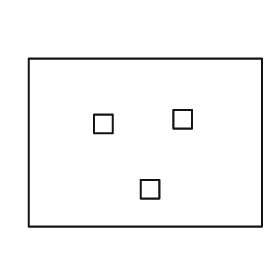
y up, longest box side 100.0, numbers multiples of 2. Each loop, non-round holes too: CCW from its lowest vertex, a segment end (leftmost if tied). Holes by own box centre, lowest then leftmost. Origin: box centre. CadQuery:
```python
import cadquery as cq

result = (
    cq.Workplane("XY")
    .moveTo(-50.0, -36.0)
    .lineTo(50.0, -36.0)
    .lineTo(50.0, 36.0)
    .lineTo(-50.0, 36.0)
    .close()
    .moveTo(-2.0, -24.0)
    .lineTo(6.0, -24.0)
    .lineTo(6.0, -16.0)
    .lineTo(-2.0, -16.0)
    .close()
    .moveTo(-22.0, 4.0)
    .lineTo(-14.0, 4.0)
    .lineTo(-14.0, 12.0)
    .lineTo(-22.0, 12.0)
    .close()
    .moveTo(12.0, 6.0)
    .lineTo(20.0, 6.0)
    .lineTo(20.0, 14.0)
    .lineTo(12.0, 14.0)
    .close()
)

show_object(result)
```